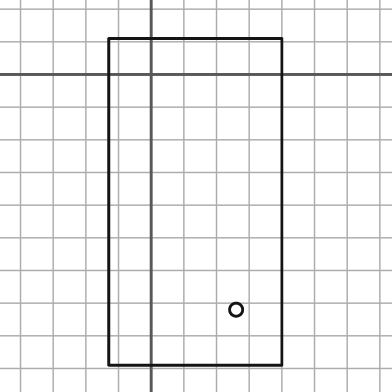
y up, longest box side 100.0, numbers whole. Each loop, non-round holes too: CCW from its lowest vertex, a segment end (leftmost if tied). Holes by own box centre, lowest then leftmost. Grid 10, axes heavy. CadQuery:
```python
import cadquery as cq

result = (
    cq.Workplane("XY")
    .moveTo(-13.0, -89.0)
    .lineTo(40.0, -89.0)
    .lineTo(40.0, 11.0)
    .lineTo(-13.0, 11.0)
    .close()
    .moveTo(26.0, -72.0)
    .circle(2.0)
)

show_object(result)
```